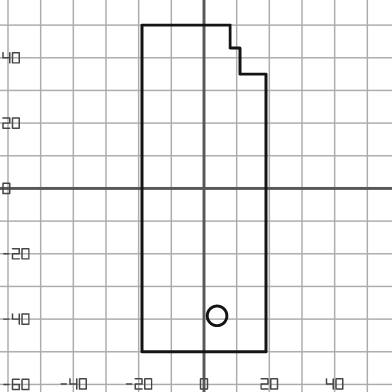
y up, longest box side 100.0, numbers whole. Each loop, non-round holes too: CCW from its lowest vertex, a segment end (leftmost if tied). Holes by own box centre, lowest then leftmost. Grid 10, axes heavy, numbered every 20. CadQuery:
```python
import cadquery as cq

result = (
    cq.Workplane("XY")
    .moveTo(-19.0, -50.0)
    .lineTo(19.0, -50.0)
    .lineTo(19.0, 35.0)
    .lineTo(11.0, 35.0)
    .lineTo(11.0, 43.0)
    .lineTo(8.0, 43.0)
    .lineTo(8.0, 50.0)
    .lineTo(-19.0, 50.0)
    .close()
    .moveTo(4.0, -39.0)
    .circle(3.0)
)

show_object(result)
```